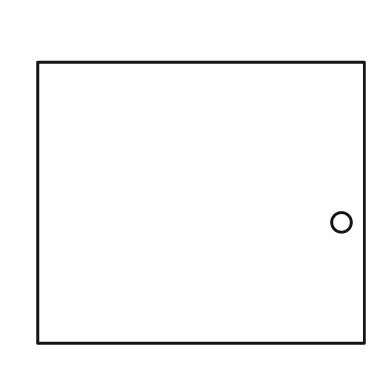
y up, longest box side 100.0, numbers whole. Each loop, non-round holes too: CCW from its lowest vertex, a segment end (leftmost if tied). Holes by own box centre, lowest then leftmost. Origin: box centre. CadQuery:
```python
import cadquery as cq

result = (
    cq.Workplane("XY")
    .moveTo(-50.0, -43.0)
    .lineTo(50.0, -43.0)
    .lineTo(50.0, 43.0)
    .lineTo(-50.0, 43.0)
    .close()
    .moveTo(43.0, -6.0)
    .circle(3.0)
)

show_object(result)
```